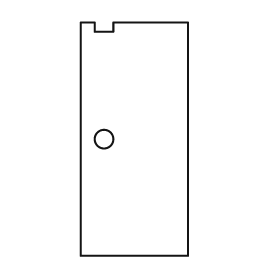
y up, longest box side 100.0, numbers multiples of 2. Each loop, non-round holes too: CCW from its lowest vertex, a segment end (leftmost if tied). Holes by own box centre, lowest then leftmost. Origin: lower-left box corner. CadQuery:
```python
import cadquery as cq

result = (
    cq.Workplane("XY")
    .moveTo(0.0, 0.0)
    .lineTo(46.0, 0.0)
    .lineTo(46.0, 100.0)
    .lineTo(14.0, 100.0)
    .lineTo(14.0, 96.0)
    .lineTo(6.0, 96.0)
    .lineTo(6.0, 100.0)
    .lineTo(0.0, 100.0)
    .close()
    .moveTo(10.0, 50.0)
    .circle(4.0)
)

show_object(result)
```